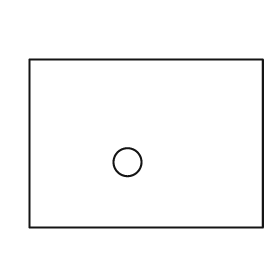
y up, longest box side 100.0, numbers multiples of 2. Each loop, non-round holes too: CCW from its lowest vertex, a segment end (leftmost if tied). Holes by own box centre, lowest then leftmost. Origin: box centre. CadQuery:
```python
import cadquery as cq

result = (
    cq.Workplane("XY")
    .moveTo(-50.0, -36.0)
    .lineTo(50.0, -36.0)
    .lineTo(50.0, 36.0)
    .lineTo(-50.0, 36.0)
    .close()
    .moveTo(-8.0, -8.0)
    .circle(6.0)
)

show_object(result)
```